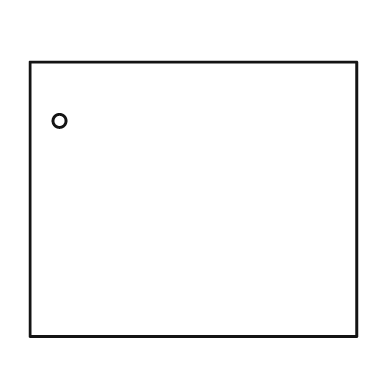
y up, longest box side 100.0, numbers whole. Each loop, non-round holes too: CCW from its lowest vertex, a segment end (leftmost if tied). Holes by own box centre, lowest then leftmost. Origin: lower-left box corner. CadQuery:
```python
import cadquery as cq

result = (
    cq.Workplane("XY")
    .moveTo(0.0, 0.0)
    .lineTo(100.0, 0.0)
    .lineTo(100.0, 84.0)
    .lineTo(0.0, 84.0)
    .close()
    .moveTo(9.0, 66.0)
    .circle(2.0)
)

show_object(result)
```